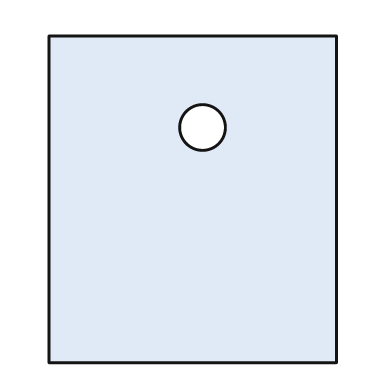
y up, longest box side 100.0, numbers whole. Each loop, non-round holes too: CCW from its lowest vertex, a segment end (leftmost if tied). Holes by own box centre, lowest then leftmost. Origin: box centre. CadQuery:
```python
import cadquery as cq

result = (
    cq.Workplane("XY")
    .moveTo(-44.0, -50.0)
    .lineTo(44.0, -50.0)
    .lineTo(44.0, 50.0)
    .lineTo(-44.0, 50.0)
    .close()
    .moveTo(3.0, 22.0)
    .circle(7.0)
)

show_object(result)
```